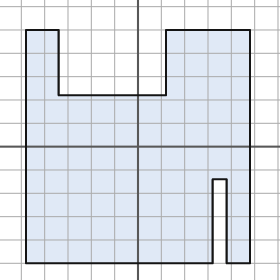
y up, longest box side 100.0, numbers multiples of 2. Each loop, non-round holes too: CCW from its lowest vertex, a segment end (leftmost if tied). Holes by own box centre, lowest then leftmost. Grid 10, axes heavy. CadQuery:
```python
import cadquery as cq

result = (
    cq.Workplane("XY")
    .moveTo(-48.0, -50.0)
    .lineTo(32.0, -50.0)
    .lineTo(32.0, -14.0)
    .lineTo(38.0, -14.0)
    .lineTo(38.0, -50.0)
    .lineTo(48.0, -50.0)
    .lineTo(48.0, 50.0)
    .lineTo(12.0, 50.0)
    .lineTo(12.0, 22.0)
    .lineTo(-34.0, 22.0)
    .lineTo(-34.0, 50.0)
    .lineTo(-48.0, 50.0)
    .close()
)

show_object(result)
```